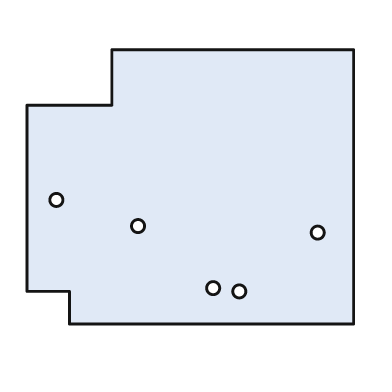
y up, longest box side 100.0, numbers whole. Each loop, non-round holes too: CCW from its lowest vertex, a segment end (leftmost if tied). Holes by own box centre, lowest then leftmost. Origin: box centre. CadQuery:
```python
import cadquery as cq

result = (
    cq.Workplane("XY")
    .moveTo(-37.0, -42.0)
    .lineTo(50.0, -42.0)
    .lineTo(50.0, 42.0)
    .lineTo(-24.0, 42.0)
    .lineTo(-24.0, 25.0)
    .lineTo(-50.0, 25.0)
    .lineTo(-50.0, -32.0)
    .lineTo(-37.0, -32.0)
    .close()
    .moveTo(15.0, -32.0)
    .circle(2.0)
    .moveTo(7.0, -31.0)
    .circle(2.0)
    .moveTo(39.0, -14.0)
    .circle(2.0)
    .moveTo(-16.0, -12.0)
    .circle(2.0)
    .moveTo(-41.0, -4.0)
    .circle(2.0)
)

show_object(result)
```